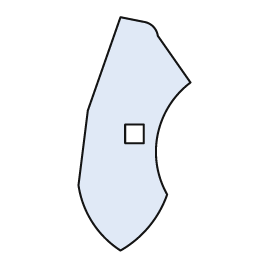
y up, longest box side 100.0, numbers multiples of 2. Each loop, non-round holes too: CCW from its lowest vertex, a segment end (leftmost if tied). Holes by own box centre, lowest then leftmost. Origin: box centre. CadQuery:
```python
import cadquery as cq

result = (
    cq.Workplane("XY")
    .moveTo(-6.0, -50.0)
    .threePointArc((6.0, -40.0), (14.0, -26.0))
    .threePointArc((10.0, 0.0), (24.0, 22.0))
    .lineTo(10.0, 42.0)
    .threePointArc((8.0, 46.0), (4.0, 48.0))
    .lineTo(-6.0, 50.0)
    .lineTo(-20.0, 10.0)
    .lineTo(-24.0, -22.0)
    .threePointArc((-18.0, -38.0), (-6.0, -50.0))
    .close()
    .moveTo(-4.0, -4.0)
    .lineTo(4.0, -4.0)
    .lineTo(4.0, 4.0)
    .lineTo(-4.0, 4.0)
    .close()
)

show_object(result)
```